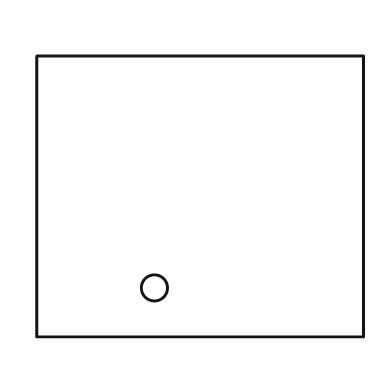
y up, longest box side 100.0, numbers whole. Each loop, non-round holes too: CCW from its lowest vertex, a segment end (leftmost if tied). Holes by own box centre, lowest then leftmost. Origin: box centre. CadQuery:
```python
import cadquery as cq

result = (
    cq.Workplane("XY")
    .moveTo(-50.0, -43.0)
    .lineTo(50.0, -43.0)
    .lineTo(50.0, 43.0)
    .lineTo(-50.0, 43.0)
    .close()
    .moveTo(-14.0, -28.0)
    .circle(4.0)
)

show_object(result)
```